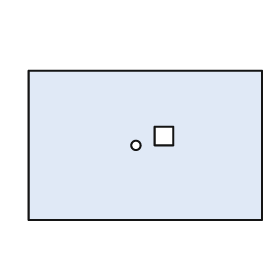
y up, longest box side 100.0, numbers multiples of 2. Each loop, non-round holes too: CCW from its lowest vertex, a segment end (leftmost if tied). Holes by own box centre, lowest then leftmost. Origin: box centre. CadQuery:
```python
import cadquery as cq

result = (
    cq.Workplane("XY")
    .moveTo(-50.0, -32.0)
    .lineTo(50.0, -32.0)
    .lineTo(50.0, 32.0)
    .lineTo(-50.0, 32.0)
    .close()
    .moveTo(-4.0, 0.0)
    .circle(2.0)
    .moveTo(4.0, 0.0)
    .lineTo(12.0, 0.0)
    .lineTo(12.0, 8.0)
    .lineTo(4.0, 8.0)
    .close()
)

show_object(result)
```